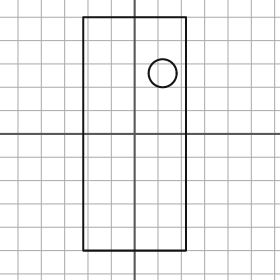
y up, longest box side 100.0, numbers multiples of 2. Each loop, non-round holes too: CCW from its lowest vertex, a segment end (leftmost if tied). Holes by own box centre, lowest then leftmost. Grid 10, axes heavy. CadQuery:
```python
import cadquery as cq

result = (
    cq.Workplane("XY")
    .moveTo(-22.0, -50.0)
    .lineTo(22.0, -50.0)
    .lineTo(22.0, 50.0)
    .lineTo(-22.0, 50.0)
    .close()
    .moveTo(12.0, 26.0)
    .circle(6.0)
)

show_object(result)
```